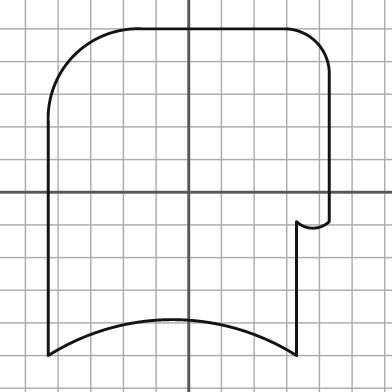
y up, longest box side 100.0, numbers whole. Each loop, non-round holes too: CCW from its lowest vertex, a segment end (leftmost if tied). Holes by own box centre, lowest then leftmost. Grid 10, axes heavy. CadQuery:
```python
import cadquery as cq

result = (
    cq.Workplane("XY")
    .moveTo(-43.0, -50.0)
    .threePointArc((-5.0, -39.0), (33.0, -50.0))
    .lineTo(33.0, -9.0)
    .threePointArc((38.0, -11.0), (43.0, -9.0))
    .lineTo(43.0, 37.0)
    .threePointArc((39.0, 46.0), (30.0, 50.0))
    .lineTo(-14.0, 50.0)
    .threePointArc((-35.0, 42.0), (-43.0, 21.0))
    .close()
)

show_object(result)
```